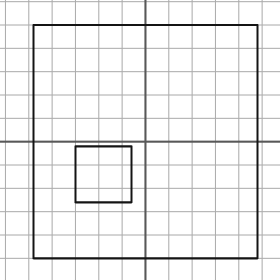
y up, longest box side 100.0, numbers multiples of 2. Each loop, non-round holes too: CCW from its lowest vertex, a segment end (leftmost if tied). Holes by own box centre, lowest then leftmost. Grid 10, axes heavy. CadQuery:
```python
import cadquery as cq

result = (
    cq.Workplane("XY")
    .moveTo(-48.0, -50.0)
    .lineTo(48.0, -50.0)
    .lineTo(48.0, 50.0)
    .lineTo(-48.0, 50.0)
    .close()
    .moveTo(-30.0, -26.0)
    .lineTo(-6.0, -26.0)
    .lineTo(-6.0, -2.0)
    .lineTo(-30.0, -2.0)
    .close()
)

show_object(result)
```